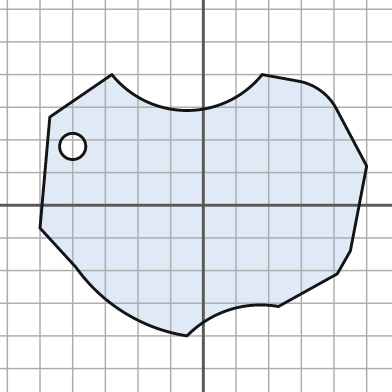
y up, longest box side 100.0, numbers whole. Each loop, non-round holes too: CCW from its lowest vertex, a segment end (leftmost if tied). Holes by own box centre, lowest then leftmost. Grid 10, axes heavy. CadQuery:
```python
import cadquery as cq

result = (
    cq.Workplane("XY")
    .moveTo(-5.0, -40.0)
    .threePointArc((8.0, -32.0), (23.0, -31.0))
    .lineTo(41.0, -21.0)
    .lineTo(45.0, -14.0)
    .lineTo(50.0, 12.0)
    .lineTo(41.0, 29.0)
    .threePointArc((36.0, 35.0), (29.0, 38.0))
    .lineTo(18.0, 40.0)
    .threePointArc((-5.0, 29.0), (-28.0, 40.0))
    .lineTo(-47.0, 27.0)
    .lineTo(-50.0, -7.0)
    .lineTo(-39.0, -19.0)
    .threePointArc((-24.0, -33.0), (-5.0, -40.0))
    .close()
    .moveTo(-40.0, 18.0)
    .circle(4.0)
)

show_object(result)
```